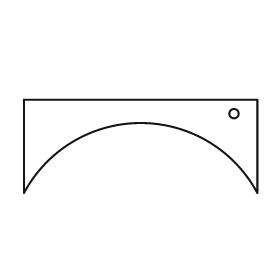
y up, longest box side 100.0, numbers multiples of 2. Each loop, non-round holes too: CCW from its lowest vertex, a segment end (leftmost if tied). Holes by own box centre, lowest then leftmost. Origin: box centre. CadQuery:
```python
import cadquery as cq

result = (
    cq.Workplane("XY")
    .moveTo(-50.0, -20.0)
    .threePointArc((0.0, 10.0), (50.0, -20.0))
    .lineTo(50.0, 20.0)
    .lineTo(-50.0, 20.0)
    .close()
    .moveTo(40.0, 14.0)
    .circle(2.0)
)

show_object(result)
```